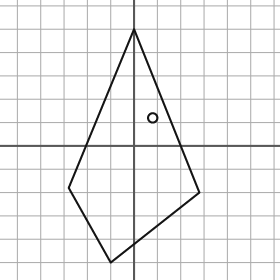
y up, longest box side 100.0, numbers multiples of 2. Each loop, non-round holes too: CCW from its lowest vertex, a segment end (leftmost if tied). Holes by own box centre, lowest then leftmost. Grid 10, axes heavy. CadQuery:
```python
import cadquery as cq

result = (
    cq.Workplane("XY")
    .moveTo(-10.0, -50.0)
    .lineTo(28.0, -20.0)
    .lineTo(0.0, 50.0)
    .lineTo(-28.0, -18.0)
    .close()
    .moveTo(8.0, 12.0)
    .circle(2.0)
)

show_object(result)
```